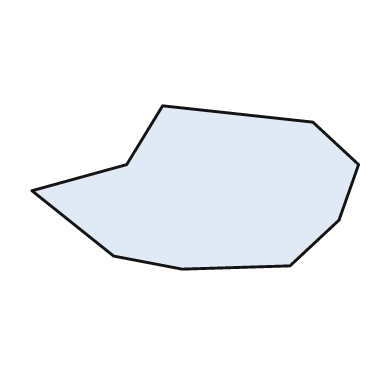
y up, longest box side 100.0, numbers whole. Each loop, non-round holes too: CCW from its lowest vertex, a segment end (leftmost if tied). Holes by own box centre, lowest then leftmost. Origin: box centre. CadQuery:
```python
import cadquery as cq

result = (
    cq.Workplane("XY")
    .moveTo(-4.0, -25.0)
    .lineTo(29.0, -24.0)
    .lineTo(44.0, -10.0)
    .lineTo(50.0, 7.0)
    .lineTo(36.0, 20.0)
    .lineTo(-10.0, 25.0)
    .lineTo(-21.0, 7.0)
    .lineTo(-50.0, -1.0)
    .lineTo(-25.0, -21.0)
    .close()
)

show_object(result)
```